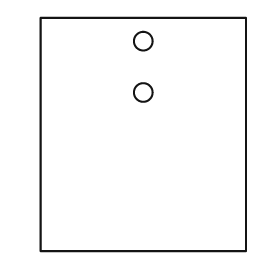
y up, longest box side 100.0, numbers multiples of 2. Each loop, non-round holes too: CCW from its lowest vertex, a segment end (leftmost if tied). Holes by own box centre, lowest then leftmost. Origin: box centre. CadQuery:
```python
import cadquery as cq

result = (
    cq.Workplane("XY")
    .moveTo(-44.0, -50.0)
    .lineTo(44.0, -50.0)
    .lineTo(44.0, 50.0)
    .lineTo(-44.0, 50.0)
    .close()
    .moveTo(0.0, 18.0)
    .circle(4.0)
    .moveTo(0.0, 40.0)
    .circle(4.0)
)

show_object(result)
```